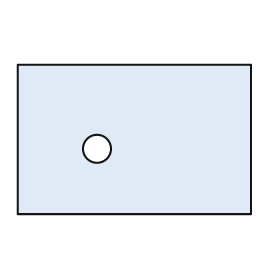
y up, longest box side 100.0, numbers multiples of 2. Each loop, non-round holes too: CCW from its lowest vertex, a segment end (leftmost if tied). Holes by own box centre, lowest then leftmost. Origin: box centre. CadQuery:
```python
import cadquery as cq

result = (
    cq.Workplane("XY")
    .moveTo(-50.0, -32.0)
    .lineTo(50.0, -32.0)
    .lineTo(50.0, 32.0)
    .lineTo(-50.0, 32.0)
    .close()
    .moveTo(-16.0, -4.0)
    .circle(6.0)
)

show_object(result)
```